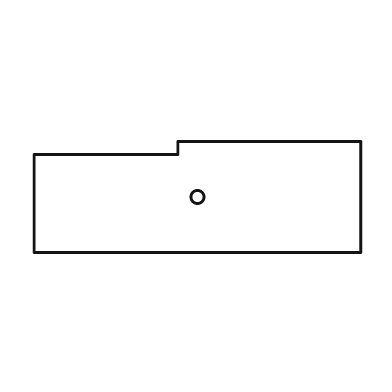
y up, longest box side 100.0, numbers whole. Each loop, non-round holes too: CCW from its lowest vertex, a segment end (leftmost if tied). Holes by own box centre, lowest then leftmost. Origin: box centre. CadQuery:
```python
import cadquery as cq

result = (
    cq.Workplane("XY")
    .moveTo(-50.0, -17.0)
    .lineTo(50.0, -17.0)
    .lineTo(50.0, 17.0)
    .lineTo(-6.0, 17.0)
    .lineTo(-6.0, 13.0)
    .lineTo(-50.0, 13.0)
    .close()
    .moveTo(0.0, 0.0)
    .circle(2.0)
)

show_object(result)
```